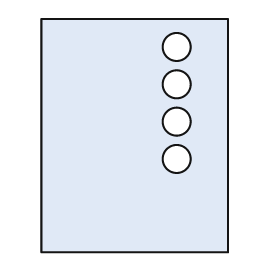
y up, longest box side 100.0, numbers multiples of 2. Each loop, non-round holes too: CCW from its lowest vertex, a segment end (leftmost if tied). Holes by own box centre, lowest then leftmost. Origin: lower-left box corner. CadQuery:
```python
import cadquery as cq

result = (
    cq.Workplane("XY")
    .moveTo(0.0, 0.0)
    .lineTo(80.0, 0.0)
    .lineTo(80.0, 100.0)
    .lineTo(0.0, 100.0)
    .close()
    .moveTo(58.0, 40.0)
    .circle(6.0)
    .moveTo(58.0, 56.0)
    .circle(6.0)
    .moveTo(58.0, 72.0)
    .circle(6.0)
    .moveTo(58.0, 88.0)
    .circle(6.0)
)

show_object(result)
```